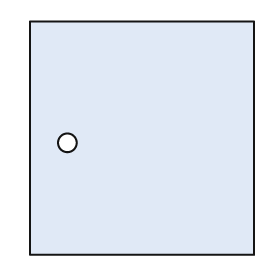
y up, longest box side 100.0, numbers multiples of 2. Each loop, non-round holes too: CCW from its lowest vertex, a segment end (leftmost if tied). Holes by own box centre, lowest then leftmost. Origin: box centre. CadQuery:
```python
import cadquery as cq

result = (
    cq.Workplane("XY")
    .moveTo(-48.0, -50.0)
    .lineTo(48.0, -50.0)
    .lineTo(48.0, 50.0)
    .lineTo(-48.0, 50.0)
    .close()
    .moveTo(-32.0, -2.0)
    .circle(4.0)
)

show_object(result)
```